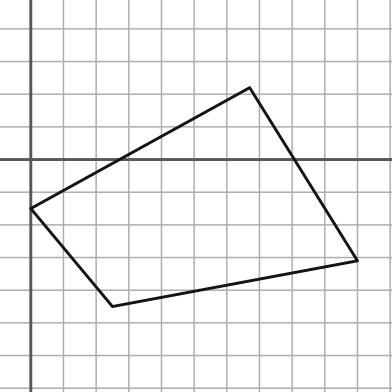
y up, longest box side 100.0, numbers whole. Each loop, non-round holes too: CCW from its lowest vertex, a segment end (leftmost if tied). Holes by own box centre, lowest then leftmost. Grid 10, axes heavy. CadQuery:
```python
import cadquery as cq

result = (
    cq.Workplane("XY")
    .moveTo(25.0, -45.0)
    .lineTo(100.0, -31.0)
    .lineTo(67.0, 22.0)
    .lineTo(0.0, -15.0)
    .close()
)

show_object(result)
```